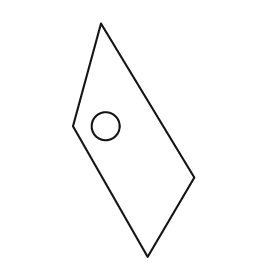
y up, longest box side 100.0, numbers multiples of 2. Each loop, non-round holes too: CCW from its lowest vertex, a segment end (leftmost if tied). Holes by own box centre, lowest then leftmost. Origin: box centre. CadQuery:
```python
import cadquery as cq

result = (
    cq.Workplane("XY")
    .moveTo(6.0, -50.0)
    .lineTo(26.0, -16.0)
    .lineTo(-14.0, 50.0)
    .lineTo(-26.0, 6.0)
    .close()
    .moveTo(-12.0, 6.0)
    .circle(6.0)
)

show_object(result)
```